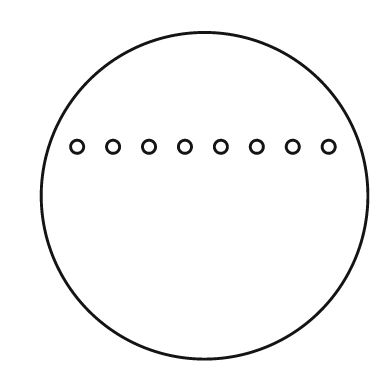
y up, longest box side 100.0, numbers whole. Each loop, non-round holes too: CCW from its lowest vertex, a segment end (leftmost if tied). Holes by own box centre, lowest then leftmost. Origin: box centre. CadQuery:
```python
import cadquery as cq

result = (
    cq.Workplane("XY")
    .moveTo(0.0, 0.0)
    .circle(50.0)
    .moveTo(-39.0, 15.0)
    .circle(2.0)
    .moveTo(-28.0, 15.0)
    .circle(2.0)
    .moveTo(-17.0, 15.0)
    .circle(2.0)
    .moveTo(-6.0, 15.0)
    .circle(2.0)
    .moveTo(5.0, 15.0)
    .circle(2.0)
    .moveTo(16.0, 15.0)
    .circle(2.0)
    .moveTo(27.0, 15.0)
    .circle(2.0)
    .moveTo(38.0, 15.0)
    .circle(2.0)
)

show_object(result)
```